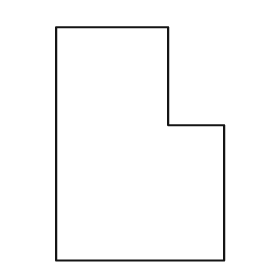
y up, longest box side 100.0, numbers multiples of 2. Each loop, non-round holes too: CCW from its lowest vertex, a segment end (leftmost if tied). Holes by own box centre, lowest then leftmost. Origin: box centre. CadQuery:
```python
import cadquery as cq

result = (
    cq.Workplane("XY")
    .moveTo(-36.0, -50.0)
    .lineTo(36.0, -50.0)
    .lineTo(36.0, 8.0)
    .lineTo(12.0, 8.0)
    .lineTo(12.0, 50.0)
    .lineTo(-36.0, 50.0)
    .close()
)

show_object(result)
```